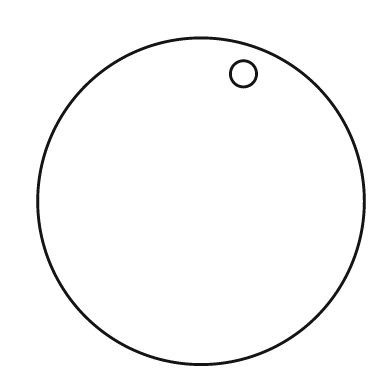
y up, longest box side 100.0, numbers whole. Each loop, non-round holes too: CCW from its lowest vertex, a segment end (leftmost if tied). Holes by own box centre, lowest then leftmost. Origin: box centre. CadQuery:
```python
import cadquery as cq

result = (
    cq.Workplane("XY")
    .moveTo(0.0, 0.0)
    .circle(50.0)
    .moveTo(13.0, 39.0)
    .circle(4.0)
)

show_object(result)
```